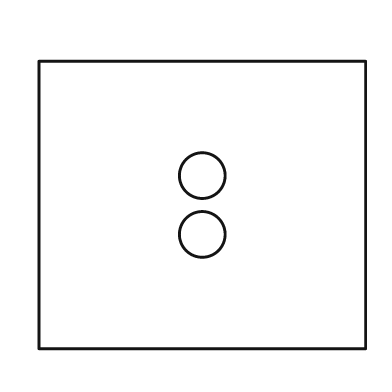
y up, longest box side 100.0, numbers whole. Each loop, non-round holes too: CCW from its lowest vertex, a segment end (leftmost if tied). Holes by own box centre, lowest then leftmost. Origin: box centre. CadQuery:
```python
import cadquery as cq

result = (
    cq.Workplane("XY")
    .moveTo(-50.0, -44.0)
    .lineTo(50.0, -44.0)
    .lineTo(50.0, 44.0)
    .lineTo(-50.0, 44.0)
    .close()
    .moveTo(0.0, -9.0)
    .circle(7.0)
    .moveTo(0.0, 9.0)
    .circle(7.0)
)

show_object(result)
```